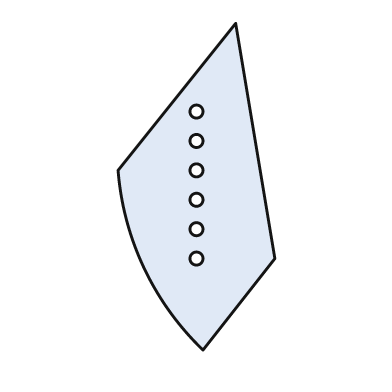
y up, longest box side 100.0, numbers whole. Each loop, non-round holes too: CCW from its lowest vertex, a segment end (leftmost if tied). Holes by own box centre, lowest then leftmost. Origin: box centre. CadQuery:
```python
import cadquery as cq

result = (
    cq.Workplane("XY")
    .moveTo(2.0, -50.0)
    .lineTo(24.0, -22.0)
    .lineTo(12.0, 50.0)
    .lineTo(-24.0, 5.0)
    .threePointArc((-16.0, -25.0), (2.0, -50.0))
    .close()
    .moveTo(0.0, -22.0)
    .circle(2.0)
    .moveTo(0.0, -13.0)
    .circle(2.0)
    .moveTo(0.0, -4.0)
    .circle(2.0)
    .moveTo(0.0, 5.0)
    .circle(2.0)
    .moveTo(0.0, 14.0)
    .circle(2.0)
    .moveTo(0.0, 23.0)
    .circle(2.0)
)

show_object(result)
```